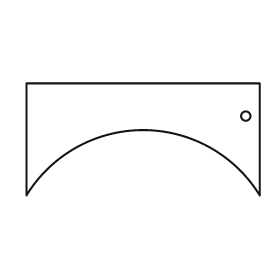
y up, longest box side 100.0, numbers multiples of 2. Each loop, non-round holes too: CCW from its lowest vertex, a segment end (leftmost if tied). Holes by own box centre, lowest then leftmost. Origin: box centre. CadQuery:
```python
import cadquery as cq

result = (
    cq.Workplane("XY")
    .moveTo(-50.0, -24.0)
    .threePointArc((0.0, 4.0), (50.0, -24.0))
    .lineTo(50.0, 24.0)
    .lineTo(-50.0, 24.0)
    .close()
    .moveTo(44.0, 10.0)
    .circle(2.0)
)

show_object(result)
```